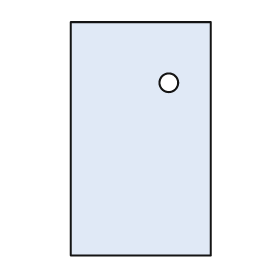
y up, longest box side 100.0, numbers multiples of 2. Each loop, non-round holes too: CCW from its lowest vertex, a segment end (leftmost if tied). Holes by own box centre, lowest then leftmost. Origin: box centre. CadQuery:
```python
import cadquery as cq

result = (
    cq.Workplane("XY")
    .moveTo(-30.0, -50.0)
    .lineTo(30.0, -50.0)
    .lineTo(30.0, 50.0)
    .lineTo(-30.0, 50.0)
    .close()
    .moveTo(12.0, 24.0)
    .circle(4.0)
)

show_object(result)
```